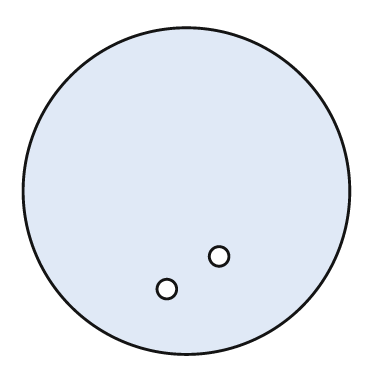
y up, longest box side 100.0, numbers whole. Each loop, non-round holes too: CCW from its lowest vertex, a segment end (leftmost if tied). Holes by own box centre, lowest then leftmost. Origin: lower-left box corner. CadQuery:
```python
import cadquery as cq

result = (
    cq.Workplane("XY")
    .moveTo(50.0, 50.0)
    .circle(50.0)
    .moveTo(44.0, 20.0)
    .circle(3.0)
    .moveTo(60.0, 30.0)
    .circle(3.0)
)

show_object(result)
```